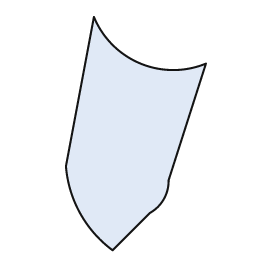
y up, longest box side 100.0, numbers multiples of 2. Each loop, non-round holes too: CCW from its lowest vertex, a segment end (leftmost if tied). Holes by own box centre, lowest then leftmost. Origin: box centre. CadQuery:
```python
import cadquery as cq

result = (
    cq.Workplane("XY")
    .moveTo(-10.0, -50.0)
    .lineTo(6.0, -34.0)
    .threePointArc((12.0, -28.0), (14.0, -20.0))
    .lineTo(30.0, 30.0)
    .threePointArc((2.0, 30.0), (-18.0, 50.0))
    .lineTo(-30.0, -14.0)
    .threePointArc((-24.0, -34.0), (-10.0, -50.0))
    .close()
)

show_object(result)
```